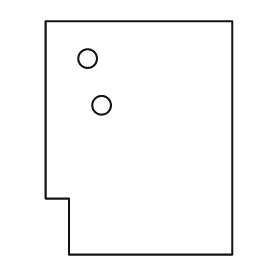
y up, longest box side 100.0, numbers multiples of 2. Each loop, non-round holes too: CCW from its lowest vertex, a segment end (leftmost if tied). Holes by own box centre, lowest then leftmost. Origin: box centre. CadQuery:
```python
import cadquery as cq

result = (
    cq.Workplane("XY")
    .moveTo(-30.0, -50.0)
    .lineTo(40.0, -50.0)
    .lineTo(40.0, 50.0)
    .lineTo(-40.0, 50.0)
    .lineTo(-40.0, -26.0)
    .lineTo(-30.0, -26.0)
    .close()
    .moveTo(-16.0, 14.0)
    .circle(4.0)
    .moveTo(-22.0, 34.0)
    .circle(4.0)
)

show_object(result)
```